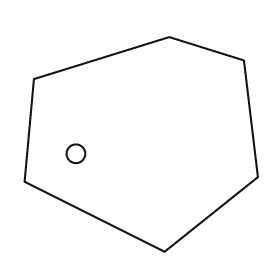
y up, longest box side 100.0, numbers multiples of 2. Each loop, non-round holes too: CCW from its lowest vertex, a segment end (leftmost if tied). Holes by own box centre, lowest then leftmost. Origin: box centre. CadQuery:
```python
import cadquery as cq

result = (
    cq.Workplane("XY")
    .moveTo(10.0, -46.0)
    .lineTo(50.0, -14.0)
    .lineTo(44.0, 36.0)
    .lineTo(12.0, 46.0)
    .lineTo(-46.0, 28.0)
    .lineTo(-50.0, -16.0)
    .close()
    .moveTo(-28.0, -4.0)
    .circle(4.0)
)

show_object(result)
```